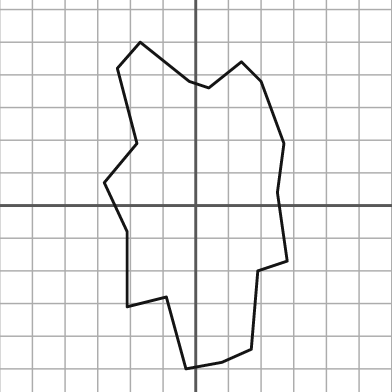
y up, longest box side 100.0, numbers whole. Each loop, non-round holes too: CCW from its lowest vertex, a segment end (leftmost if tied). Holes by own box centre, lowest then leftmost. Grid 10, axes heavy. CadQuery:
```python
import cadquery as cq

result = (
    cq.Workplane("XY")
    .moveTo(-3.0, -50.0)
    .lineTo(8.0, -48.0)
    .lineTo(17.0, -44.0)
    .lineTo(19.0, -20.0)
    .lineTo(28.0, -17.0)
    .lineTo(25.0, 4.0)
    .lineTo(27.0, 19.0)
    .lineTo(20.0, 38.0)
    .lineTo(14.0, 44.0)
    .lineTo(4.0, 36.0)
    .lineTo(-2.0, 38.0)
    .lineTo(-17.0, 50.0)
    .lineTo(-24.0, 42.0)
    .lineTo(-18.0, 19.0)
    .lineTo(-28.0, 7.0)
    .lineTo(-21.0, -8.0)
    .lineTo(-21.0, -31.0)
    .lineTo(-9.0, -28.0)
    .close()
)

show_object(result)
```